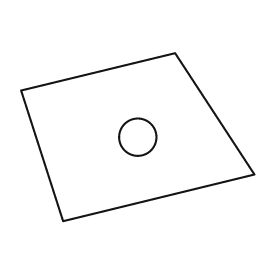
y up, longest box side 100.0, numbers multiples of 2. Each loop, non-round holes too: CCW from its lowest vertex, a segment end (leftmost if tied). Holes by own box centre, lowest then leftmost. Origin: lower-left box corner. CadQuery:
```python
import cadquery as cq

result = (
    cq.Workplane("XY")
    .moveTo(18.0, 0.0)
    .lineTo(100.0, 20.0)
    .lineTo(66.0, 72.0)
    .lineTo(0.0, 56.0)
    .close()
    .moveTo(50.0, 36.0)
    .circle(8.0)
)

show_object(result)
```